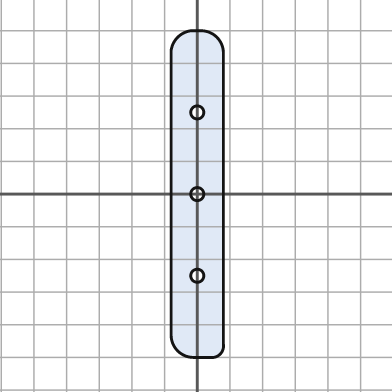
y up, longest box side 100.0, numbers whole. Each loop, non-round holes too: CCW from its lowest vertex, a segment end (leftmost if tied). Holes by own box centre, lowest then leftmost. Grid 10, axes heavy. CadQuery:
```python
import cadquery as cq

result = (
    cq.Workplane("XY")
    .moveTo(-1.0, -50.0)
    .lineTo(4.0, -50.0)
    .threePointArc((7.0, -49.0), (8.0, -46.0))
    .lineTo(8.0, 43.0)
    .threePointArc((6.0, 48.0), (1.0, 50.0))
    .lineTo(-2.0, 50.0)
    .threePointArc((-6.0, 48.0), (-8.0, 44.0))
    .lineTo(-8.0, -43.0)
    .threePointArc((-6.0, -48.0), (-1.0, -50.0))
    .close()
    .moveTo(0.0, -25.0)
    .circle(2.0)
    .moveTo(0.0, 0.0)
    .circle(2.0)
    .moveTo(0.0, 25.0)
    .circle(2.0)
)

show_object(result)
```